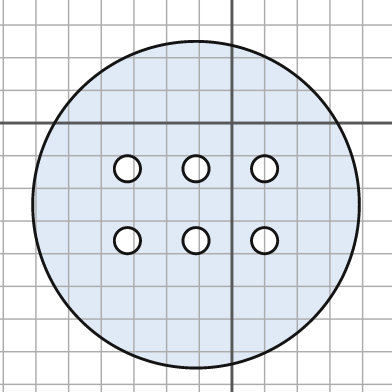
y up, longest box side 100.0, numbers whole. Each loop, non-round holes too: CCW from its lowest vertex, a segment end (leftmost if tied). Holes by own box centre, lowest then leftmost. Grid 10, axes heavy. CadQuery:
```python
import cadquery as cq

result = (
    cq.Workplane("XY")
    .moveTo(-11.0, -25.0)
    .circle(50.0)
    .moveTo(-32.0, -36.0)
    .circle(4.0)
    .moveTo(-11.0, -36.0)
    .circle(4.0)
    .moveTo(10.0, -36.0)
    .circle(4.0)
    .moveTo(-32.0, -14.0)
    .circle(4.0)
    .moveTo(-11.0, -14.0)
    .circle(4.0)
    .moveTo(10.0, -14.0)
    .circle(4.0)
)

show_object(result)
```